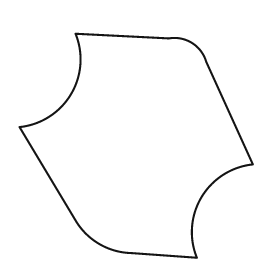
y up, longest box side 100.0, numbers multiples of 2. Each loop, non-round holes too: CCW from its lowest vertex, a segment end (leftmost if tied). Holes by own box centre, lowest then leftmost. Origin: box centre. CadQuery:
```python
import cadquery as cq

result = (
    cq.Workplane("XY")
    .moveTo(26.0, -48.0)
    .threePointArc((28.0, -22.0), (50.0, -8.0))
    .lineTo(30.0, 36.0)
    .threePointArc((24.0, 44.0), (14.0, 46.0))
    .lineTo(-26.0, 48.0)
    .threePointArc((-28.0, 22.0), (-50.0, 8.0))
    .lineTo(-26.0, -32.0)
    .threePointArc((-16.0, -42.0), (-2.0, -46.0))
    .close()
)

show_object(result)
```